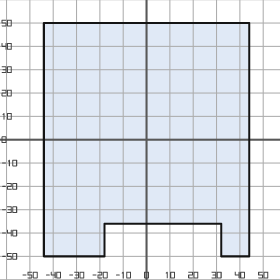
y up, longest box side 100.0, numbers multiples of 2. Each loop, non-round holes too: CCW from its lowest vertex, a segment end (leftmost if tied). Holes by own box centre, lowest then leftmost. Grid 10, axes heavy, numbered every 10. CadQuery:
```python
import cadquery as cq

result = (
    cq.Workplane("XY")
    .moveTo(-44.0, -50.0)
    .lineTo(-18.0, -50.0)
    .lineTo(-18.0, -36.0)
    .lineTo(32.0, -36.0)
    .lineTo(32.0, -50.0)
    .lineTo(44.0, -50.0)
    .lineTo(44.0, 50.0)
    .lineTo(-44.0, 50.0)
    .close()
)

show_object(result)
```